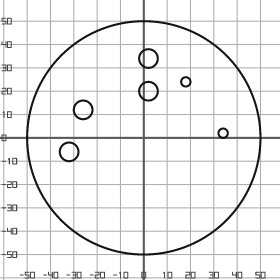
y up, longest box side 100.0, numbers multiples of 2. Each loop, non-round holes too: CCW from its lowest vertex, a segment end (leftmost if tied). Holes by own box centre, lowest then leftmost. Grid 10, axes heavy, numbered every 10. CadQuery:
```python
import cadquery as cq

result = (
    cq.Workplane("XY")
    .moveTo(0.0, 0.0)
    .circle(50.0)
    .moveTo(-32.0, -6.0)
    .circle(4.0)
    .moveTo(34.0, 2.0)
    .circle(2.0)
    .moveTo(-26.0, 12.0)
    .circle(4.0)
    .moveTo(2.0, 20.0)
    .circle(4.0)
    .moveTo(18.0, 24.0)
    .circle(2.0)
    .moveTo(2.0, 34.0)
    .circle(4.0)
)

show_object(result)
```